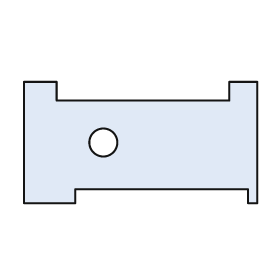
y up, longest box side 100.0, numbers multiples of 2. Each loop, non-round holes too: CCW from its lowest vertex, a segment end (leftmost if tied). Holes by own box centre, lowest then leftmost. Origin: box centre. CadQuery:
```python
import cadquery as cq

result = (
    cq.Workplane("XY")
    .moveTo(-50.0, -26.0)
    .lineTo(-28.0, -26.0)
    .lineTo(-28.0, -20.0)
    .lineTo(46.0, -20.0)
    .lineTo(46.0, -26.0)
    .lineTo(50.0, -26.0)
    .lineTo(50.0, 26.0)
    .lineTo(38.0, 26.0)
    .lineTo(38.0, 18.0)
    .lineTo(-36.0, 18.0)
    .lineTo(-36.0, 26.0)
    .lineTo(-50.0, 26.0)
    .close()
    .moveTo(-16.0, 0.0)
    .circle(6.0)
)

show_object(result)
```